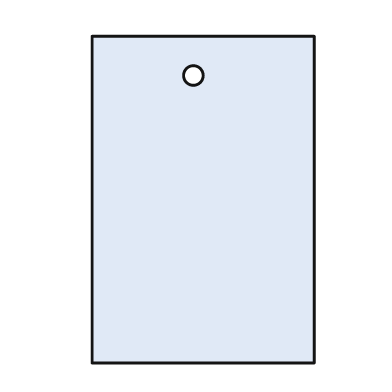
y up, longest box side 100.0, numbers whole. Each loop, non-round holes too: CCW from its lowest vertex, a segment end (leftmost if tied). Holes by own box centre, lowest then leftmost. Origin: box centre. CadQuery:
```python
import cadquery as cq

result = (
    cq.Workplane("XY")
    .moveTo(-34.0, -50.0)
    .lineTo(34.0, -50.0)
    .lineTo(34.0, 50.0)
    .lineTo(-34.0, 50.0)
    .close()
    .moveTo(-3.0, 38.0)
    .circle(3.0)
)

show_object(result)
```